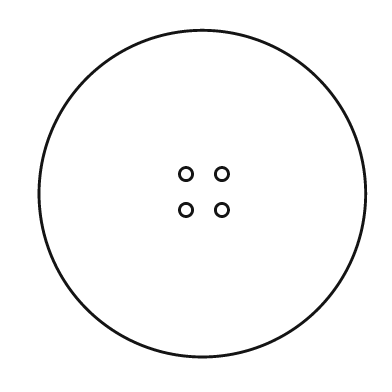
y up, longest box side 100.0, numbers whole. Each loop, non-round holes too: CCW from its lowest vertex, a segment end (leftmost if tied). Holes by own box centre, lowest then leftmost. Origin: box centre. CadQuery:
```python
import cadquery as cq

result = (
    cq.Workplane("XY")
    .moveTo(0.0, 0.0)
    .circle(50.0)
    .moveTo(-5.0, -5.0)
    .circle(2.0)
    .moveTo(6.0, -5.0)
    .circle(2.0)
    .moveTo(-5.0, 6.0)
    .circle(2.0)
    .moveTo(6.0, 6.0)
    .circle(2.0)
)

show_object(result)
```